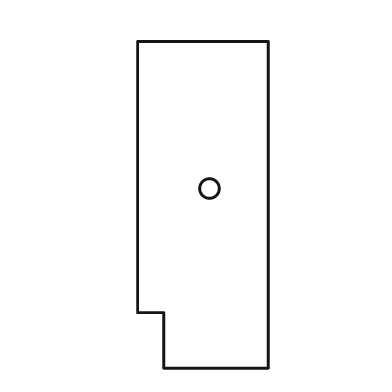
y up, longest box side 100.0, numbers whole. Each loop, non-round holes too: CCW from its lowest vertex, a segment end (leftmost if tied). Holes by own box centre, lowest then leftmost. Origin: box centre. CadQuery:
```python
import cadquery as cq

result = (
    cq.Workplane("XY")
    .moveTo(-12.0, -50.0)
    .lineTo(20.0, -50.0)
    .lineTo(20.0, 50.0)
    .lineTo(-20.0, 50.0)
    .lineTo(-20.0, -33.0)
    .lineTo(-12.0, -33.0)
    .close()
    .moveTo(2.0, 5.0)
    .circle(3.0)
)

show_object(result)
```